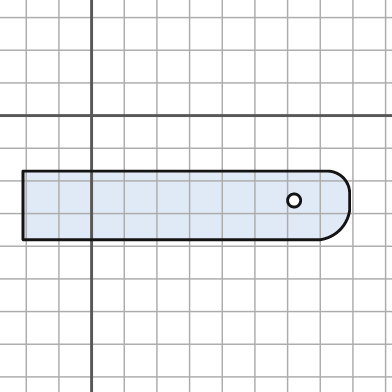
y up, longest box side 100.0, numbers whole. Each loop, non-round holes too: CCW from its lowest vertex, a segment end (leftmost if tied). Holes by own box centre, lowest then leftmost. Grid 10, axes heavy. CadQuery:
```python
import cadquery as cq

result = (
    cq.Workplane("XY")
    .moveTo(-21.0, -38.0)
    .lineTo(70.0, -38.0)
    .threePointArc((76.0, -35.0), (79.0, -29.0))
    .lineTo(79.0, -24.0)
    .threePointArc((77.0, -19.0), (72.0, -17.0))
    .lineTo(-21.0, -17.0)
    .close()
    .moveTo(62.0, -26.0)
    .circle(2.0)
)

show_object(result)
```